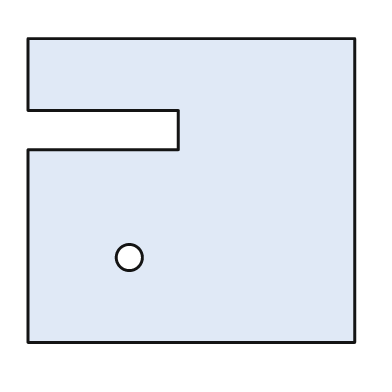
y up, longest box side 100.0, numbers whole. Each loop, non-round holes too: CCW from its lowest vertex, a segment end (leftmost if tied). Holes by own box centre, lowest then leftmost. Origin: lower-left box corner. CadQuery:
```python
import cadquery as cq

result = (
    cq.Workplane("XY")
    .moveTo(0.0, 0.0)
    .lineTo(100.0, 0.0)
    .lineTo(100.0, 93.0)
    .lineTo(0.0, 93.0)
    .lineTo(0.0, 71.0)
    .lineTo(46.0, 71.0)
    .lineTo(46.0, 59.0)
    .lineTo(0.0, 59.0)
    .close()
    .moveTo(31.0, 26.0)
    .circle(4.0)
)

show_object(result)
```